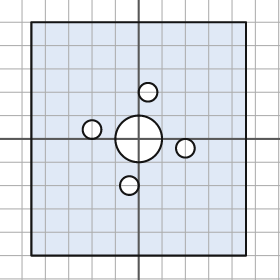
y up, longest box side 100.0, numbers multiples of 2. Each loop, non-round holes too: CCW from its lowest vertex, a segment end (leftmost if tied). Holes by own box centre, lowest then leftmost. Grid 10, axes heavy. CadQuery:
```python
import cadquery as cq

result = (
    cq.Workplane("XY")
    .moveTo(-46.0, -50.0)
    .lineTo(46.0, -50.0)
    .lineTo(46.0, 50.0)
    .lineTo(-46.0, 50.0)
    .close()
    .moveTo(-4.0, -20.0)
    .circle(4.0)
    .moveTo(20.0, -4.0)
    .circle(4.0)
    .moveTo(0.0, 0.0)
    .circle(10.0)
    .moveTo(-20.0, 4.0)
    .circle(4.0)
    .moveTo(4.0, 20.0)
    .circle(4.0)
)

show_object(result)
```